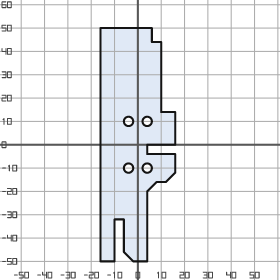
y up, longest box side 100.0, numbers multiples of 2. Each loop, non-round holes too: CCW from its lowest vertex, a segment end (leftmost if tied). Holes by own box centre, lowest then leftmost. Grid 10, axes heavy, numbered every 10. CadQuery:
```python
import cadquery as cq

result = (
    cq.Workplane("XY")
    .moveTo(-16.0, -50.0)
    .lineTo(-10.0, -50.0)
    .lineTo(-10.0, -32.0)
    .lineTo(-6.0, -32.0)
    .lineTo(-6.0, -46.0)
    .lineTo(-2.0, -50.0)
    .lineTo(4.0, -50.0)
    .lineTo(4.0, -20.0)
    .lineTo(8.0, -16.0)
    .lineTo(12.0, -16.0)
    .lineTo(16.0, -12.0)
    .lineTo(16.0, -4.0)
    .lineTo(4.0, -4.0)
    .lineTo(4.0, 0.0)
    .lineTo(16.0, 0.0)
    .lineTo(16.0, 14.0)
    .lineTo(10.0, 14.0)
    .lineTo(10.0, 44.0)
    .lineTo(6.0, 44.0)
    .lineTo(6.0, 50.0)
    .lineTo(-16.0, 50.0)
    .close()
    .moveTo(-4.0, -10.0)
    .circle(2.0)
    .moveTo(4.0, -10.0)
    .circle(2.0)
    .moveTo(-4.0, 10.0)
    .circle(2.0)
    .moveTo(4.0, 10.0)
    .circle(2.0)
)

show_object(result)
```